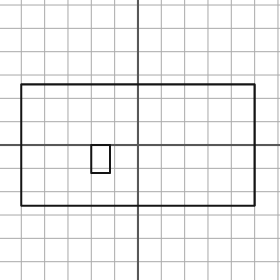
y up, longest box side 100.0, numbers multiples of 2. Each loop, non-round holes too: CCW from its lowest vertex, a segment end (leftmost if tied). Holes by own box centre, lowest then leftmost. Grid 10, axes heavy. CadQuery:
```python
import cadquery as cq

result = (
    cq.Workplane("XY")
    .moveTo(-50.0, -26.0)
    .lineTo(50.0, -26.0)
    .lineTo(50.0, 26.0)
    .lineTo(-50.0, 26.0)
    .close()
    .moveTo(-20.0, -12.0)
    .lineTo(-12.0, -12.0)
    .lineTo(-12.0, 0.0)
    .lineTo(-20.0, 0.0)
    .close()
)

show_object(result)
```